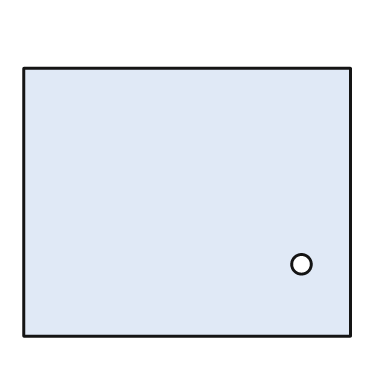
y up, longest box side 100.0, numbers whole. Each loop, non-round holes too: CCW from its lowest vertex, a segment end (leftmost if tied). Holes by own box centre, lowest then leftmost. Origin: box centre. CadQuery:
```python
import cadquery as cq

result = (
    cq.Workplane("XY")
    .moveTo(-50.0, -41.0)
    .lineTo(50.0, -41.0)
    .lineTo(50.0, 41.0)
    .lineTo(-50.0, 41.0)
    .close()
    .moveTo(35.0, -19.0)
    .circle(3.0)
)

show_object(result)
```